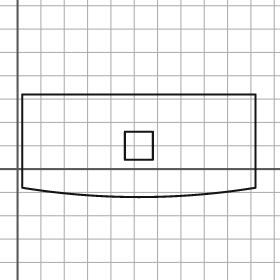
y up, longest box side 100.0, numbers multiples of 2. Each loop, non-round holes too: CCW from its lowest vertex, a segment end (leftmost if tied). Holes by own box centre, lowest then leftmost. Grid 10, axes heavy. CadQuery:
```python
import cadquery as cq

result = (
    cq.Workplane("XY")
    .moveTo(2.0, -8.0)
    .threePointArc((52.0, -12.0), (102.0, -8.0))
    .lineTo(102.0, 32.0)
    .lineTo(2.0, 32.0)
    .close()
    .moveTo(46.0, 4.0)
    .lineTo(58.0, 4.0)
    .lineTo(58.0, 16.0)
    .lineTo(46.0, 16.0)
    .close()
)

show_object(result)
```